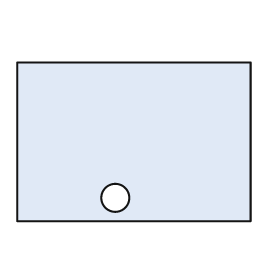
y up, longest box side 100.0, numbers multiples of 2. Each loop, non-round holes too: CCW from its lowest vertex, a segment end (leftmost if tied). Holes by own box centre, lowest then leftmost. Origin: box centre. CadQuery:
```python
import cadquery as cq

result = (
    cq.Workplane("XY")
    .moveTo(-50.0, -34.0)
    .lineTo(50.0, -34.0)
    .lineTo(50.0, 34.0)
    .lineTo(-50.0, 34.0)
    .close()
    .moveTo(-8.0, -24.0)
    .circle(6.0)
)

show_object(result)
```